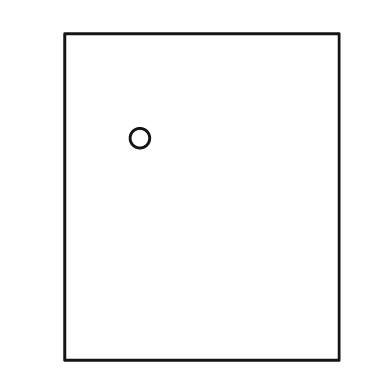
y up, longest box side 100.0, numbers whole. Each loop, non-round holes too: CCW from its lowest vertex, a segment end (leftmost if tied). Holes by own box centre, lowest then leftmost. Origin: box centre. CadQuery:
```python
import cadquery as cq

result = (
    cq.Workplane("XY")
    .moveTo(-42.0, -50.0)
    .lineTo(42.0, -50.0)
    .lineTo(42.0, 50.0)
    .lineTo(-42.0, 50.0)
    .close()
    .moveTo(-19.0, 18.0)
    .circle(3.0)
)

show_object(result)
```